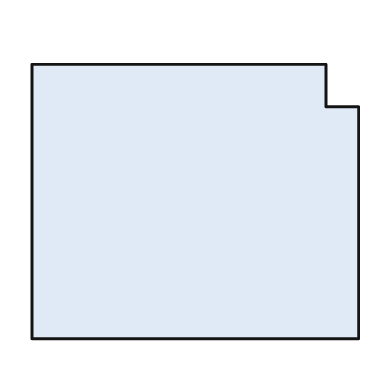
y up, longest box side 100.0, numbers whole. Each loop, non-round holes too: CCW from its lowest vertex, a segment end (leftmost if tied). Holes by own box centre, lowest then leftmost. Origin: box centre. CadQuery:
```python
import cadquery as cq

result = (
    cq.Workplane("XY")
    .moveTo(-50.0, -42.0)
    .lineTo(50.0, -42.0)
    .lineTo(50.0, 29.0)
    .lineTo(40.0, 29.0)
    .lineTo(40.0, 42.0)
    .lineTo(-50.0, 42.0)
    .close()
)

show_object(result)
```